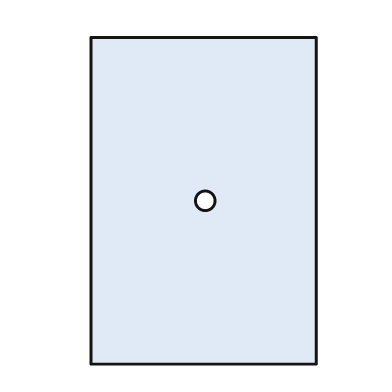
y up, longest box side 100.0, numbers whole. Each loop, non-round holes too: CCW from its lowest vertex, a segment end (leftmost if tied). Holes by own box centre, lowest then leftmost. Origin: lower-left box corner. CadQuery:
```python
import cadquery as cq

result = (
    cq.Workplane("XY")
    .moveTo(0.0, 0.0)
    .lineTo(69.0, 0.0)
    .lineTo(69.0, 100.0)
    .lineTo(0.0, 100.0)
    .close()
    .moveTo(35.0, 50.0)
    .circle(3.0)
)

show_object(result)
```